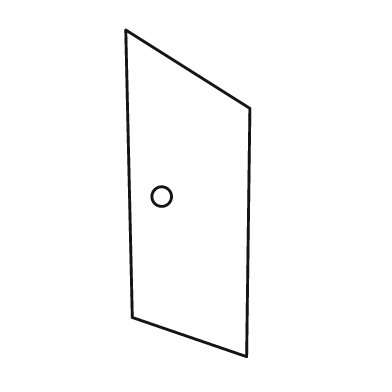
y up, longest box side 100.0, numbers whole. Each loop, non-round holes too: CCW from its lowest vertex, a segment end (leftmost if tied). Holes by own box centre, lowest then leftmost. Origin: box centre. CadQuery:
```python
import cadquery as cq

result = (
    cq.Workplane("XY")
    .moveTo(18.0, -50.0)
    .lineTo(19.0, 26.0)
    .lineTo(-19.0, 50.0)
    .lineTo(-17.0, -38.0)
    .close()
    .moveTo(-8.0, -1.0)
    .circle(3.0)
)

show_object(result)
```